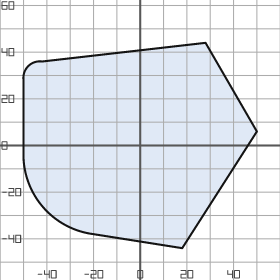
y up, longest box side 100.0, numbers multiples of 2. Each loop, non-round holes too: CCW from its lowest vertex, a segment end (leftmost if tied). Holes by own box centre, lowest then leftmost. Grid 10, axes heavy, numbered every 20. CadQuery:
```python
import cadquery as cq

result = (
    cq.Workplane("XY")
    .moveTo(18.0, -44.0)
    .lineTo(50.0, 6.0)
    .lineTo(28.0, 44.0)
    .lineTo(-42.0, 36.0)
    .threePointArc((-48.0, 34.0), (-50.0, 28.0))
    .lineTo(-50.0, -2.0)
    .threePointArc((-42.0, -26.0), (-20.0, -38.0))
    .close()
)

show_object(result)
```